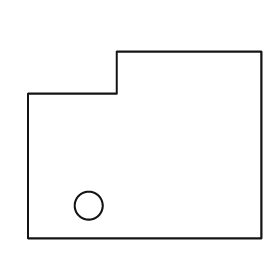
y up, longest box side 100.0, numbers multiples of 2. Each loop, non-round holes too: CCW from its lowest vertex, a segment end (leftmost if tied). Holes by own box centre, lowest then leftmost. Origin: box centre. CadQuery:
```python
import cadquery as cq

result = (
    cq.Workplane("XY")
    .moveTo(-50.0, -40.0)
    .lineTo(50.0, -40.0)
    .lineTo(50.0, 40.0)
    .lineTo(-12.0, 40.0)
    .lineTo(-12.0, 22.0)
    .lineTo(-50.0, 22.0)
    .close()
    .moveTo(-24.0, -26.0)
    .circle(6.0)
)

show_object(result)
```